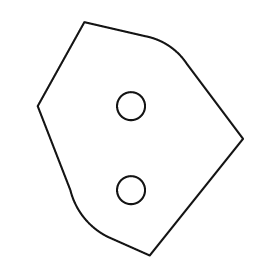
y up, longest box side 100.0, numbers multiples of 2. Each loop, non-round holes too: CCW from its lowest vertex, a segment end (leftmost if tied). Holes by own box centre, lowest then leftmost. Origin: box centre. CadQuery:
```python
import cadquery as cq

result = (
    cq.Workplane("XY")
    .moveTo(4.0, -50.0)
    .lineTo(44.0, 0.0)
    .lineTo(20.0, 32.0)
    .threePointArc((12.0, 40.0), (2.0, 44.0))
    .lineTo(-24.0, 50.0)
    .lineTo(-44.0, 14.0)
    .lineTo(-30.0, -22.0)
    .threePointArc((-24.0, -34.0), (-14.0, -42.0))
    .close()
    .moveTo(-4.0, -22.0)
    .circle(6.0)
    .moveTo(-4.0, 14.0)
    .circle(6.0)
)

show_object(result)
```